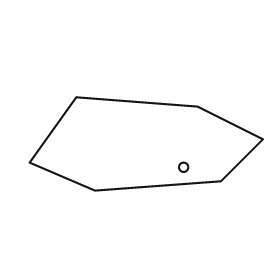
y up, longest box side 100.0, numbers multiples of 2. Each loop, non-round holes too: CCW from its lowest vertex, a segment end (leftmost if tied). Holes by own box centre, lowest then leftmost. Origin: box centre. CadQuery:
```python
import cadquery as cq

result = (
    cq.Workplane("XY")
    .moveTo(-22.0, -20.0)
    .lineTo(32.0, -16.0)
    .lineTo(50.0, 2.0)
    .lineTo(22.0, 16.0)
    .lineTo(-30.0, 20.0)
    .lineTo(-50.0, -8.0)
    .close()
    .moveTo(16.0, -10.0)
    .circle(2.0)
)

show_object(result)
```